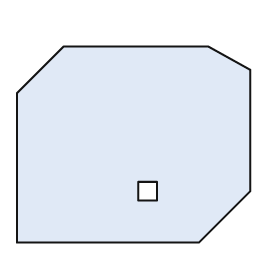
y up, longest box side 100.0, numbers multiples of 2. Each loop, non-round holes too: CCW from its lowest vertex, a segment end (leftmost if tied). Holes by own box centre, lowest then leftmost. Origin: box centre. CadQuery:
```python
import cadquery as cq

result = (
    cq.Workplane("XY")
    .moveTo(-50.0, -42.0)
    .lineTo(28.0, -42.0)
    .lineTo(50.0, -20.0)
    .lineTo(50.0, 32.0)
    .lineTo(32.0, 42.0)
    .lineTo(-30.0, 42.0)
    .lineTo(-50.0, 22.0)
    .close()
    .moveTo(2.0, -24.0)
    .lineTo(10.0, -24.0)
    .lineTo(10.0, -16.0)
    .lineTo(2.0, -16.0)
    .close()
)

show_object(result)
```